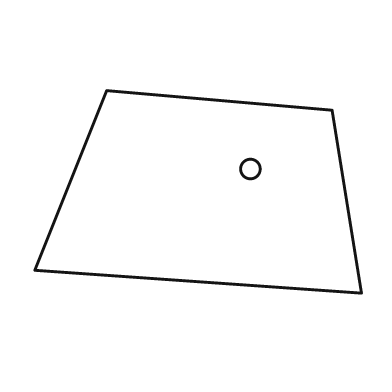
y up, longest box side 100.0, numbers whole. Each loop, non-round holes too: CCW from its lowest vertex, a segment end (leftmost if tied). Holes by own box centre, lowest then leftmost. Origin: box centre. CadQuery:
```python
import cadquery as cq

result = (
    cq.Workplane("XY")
    .moveTo(50.0, -31.0)
    .lineTo(41.0, 25.0)
    .lineTo(-28.0, 31.0)
    .lineTo(-50.0, -24.0)
    .close()
    .moveTo(16.0, 7.0)
    .circle(3.0)
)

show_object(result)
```